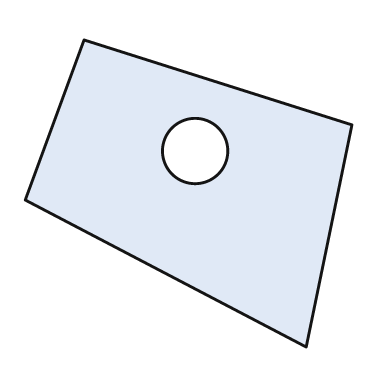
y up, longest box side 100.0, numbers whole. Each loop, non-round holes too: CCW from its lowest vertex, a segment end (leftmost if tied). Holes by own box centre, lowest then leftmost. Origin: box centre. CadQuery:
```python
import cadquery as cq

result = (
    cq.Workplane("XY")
    .moveTo(36.0, -47.0)
    .lineTo(50.0, 21.0)
    .lineTo(-32.0, 47.0)
    .lineTo(-50.0, -2.0)
    .close()
    .moveTo(2.0, 13.0)
    .circle(10.0)
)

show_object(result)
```